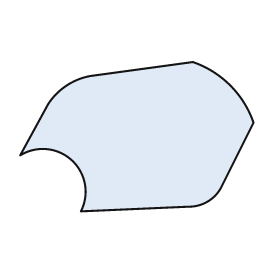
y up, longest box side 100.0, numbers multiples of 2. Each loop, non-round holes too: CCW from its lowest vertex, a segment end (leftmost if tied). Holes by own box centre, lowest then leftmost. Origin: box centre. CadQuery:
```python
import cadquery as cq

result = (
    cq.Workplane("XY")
    .moveTo(-24.0, -32.0)
    .lineTo(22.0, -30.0)
    .threePointArc((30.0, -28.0), (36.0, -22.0))
    .lineTo(50.0, 6.0)
    .threePointArc((40.0, 22.0), (24.0, 32.0))
    .lineTo(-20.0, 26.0)
    .threePointArc((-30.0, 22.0), (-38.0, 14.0))
    .lineTo(-50.0, -8.0)
    .threePointArc((-28.0, -10.0), (-24.0, -32.0))
    .close()
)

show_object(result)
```